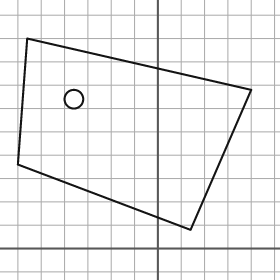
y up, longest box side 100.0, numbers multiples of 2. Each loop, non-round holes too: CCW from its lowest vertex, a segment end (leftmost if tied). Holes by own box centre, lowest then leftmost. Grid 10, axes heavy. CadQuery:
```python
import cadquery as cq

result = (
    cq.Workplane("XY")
    .moveTo(14.0, 8.0)
    .lineTo(40.0, 68.0)
    .lineTo(-56.0, 90.0)
    .lineTo(-60.0, 36.0)
    .close()
    .moveTo(-36.0, 64.0)
    .circle(4.0)
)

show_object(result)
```